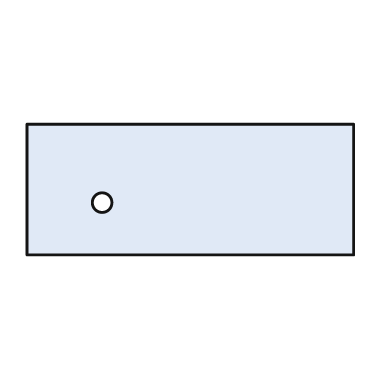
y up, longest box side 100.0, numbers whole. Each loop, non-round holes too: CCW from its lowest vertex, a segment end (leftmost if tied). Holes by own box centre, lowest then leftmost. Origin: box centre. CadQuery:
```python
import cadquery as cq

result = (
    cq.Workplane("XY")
    .moveTo(-50.0, -20.0)
    .lineTo(50.0, -20.0)
    .lineTo(50.0, 20.0)
    .lineTo(-50.0, 20.0)
    .close()
    .moveTo(-27.0, -4.0)
    .circle(3.0)
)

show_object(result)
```